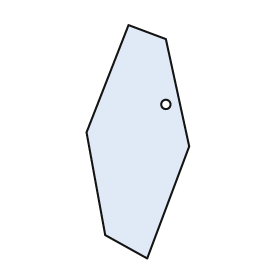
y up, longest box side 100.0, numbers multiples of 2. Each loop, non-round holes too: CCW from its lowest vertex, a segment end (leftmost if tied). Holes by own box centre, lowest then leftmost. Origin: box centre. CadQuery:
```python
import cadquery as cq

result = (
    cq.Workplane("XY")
    .moveTo(4.0, -50.0)
    .lineTo(22.0, -2.0)
    .lineTo(12.0, 44.0)
    .lineTo(-4.0, 50.0)
    .lineTo(-22.0, 4.0)
    .lineTo(-14.0, -40.0)
    .close()
    .moveTo(12.0, 16.0)
    .circle(2.0)
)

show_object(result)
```